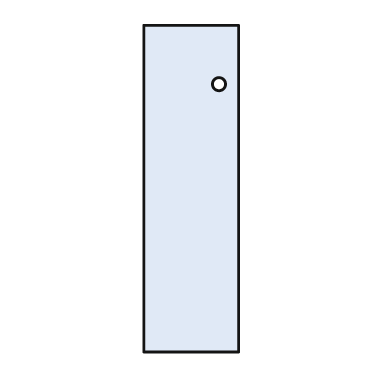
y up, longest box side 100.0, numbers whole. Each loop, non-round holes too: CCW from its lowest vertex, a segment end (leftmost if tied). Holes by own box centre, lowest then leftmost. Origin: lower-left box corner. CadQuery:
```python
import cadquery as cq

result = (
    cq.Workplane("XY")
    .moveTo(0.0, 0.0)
    .lineTo(29.0, 0.0)
    .lineTo(29.0, 100.0)
    .lineTo(0.0, 100.0)
    .close()
    .moveTo(23.0, 82.0)
    .circle(2.0)
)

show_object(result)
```